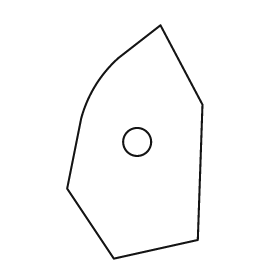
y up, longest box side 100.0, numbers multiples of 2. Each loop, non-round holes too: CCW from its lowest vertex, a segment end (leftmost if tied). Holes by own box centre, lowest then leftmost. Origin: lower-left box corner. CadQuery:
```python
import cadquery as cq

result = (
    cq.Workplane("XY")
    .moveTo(20.0, 0.0)
    .lineTo(56.0, 8.0)
    .lineTo(58.0, 66.0)
    .lineTo(40.0, 100.0)
    .lineTo(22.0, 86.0)
    .threePointArc((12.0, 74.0), (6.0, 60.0))
    .lineTo(0.0, 30.0)
    .close()
    .moveTo(30.0, 50.0)
    .circle(6.0)
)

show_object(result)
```